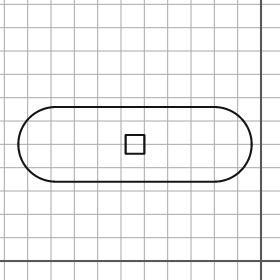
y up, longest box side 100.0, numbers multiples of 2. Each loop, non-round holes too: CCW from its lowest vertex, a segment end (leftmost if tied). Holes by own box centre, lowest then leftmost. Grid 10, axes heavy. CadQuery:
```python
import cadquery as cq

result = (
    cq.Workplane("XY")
    .moveTo(-88.0, 34.0)
    .lineTo(-20.0, 34.0)
    .threePointArc((-4.0, 50.0), (-20.0, 66.0))
    .lineTo(-88.0, 66.0)
    .threePointArc((-104.0, 50.0), (-88.0, 34.0))
    .close()
    .moveTo(-58.0, 46.0)
    .lineTo(-50.0, 46.0)
    .lineTo(-50.0, 54.0)
    .lineTo(-58.0, 54.0)
    .close()
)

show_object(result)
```